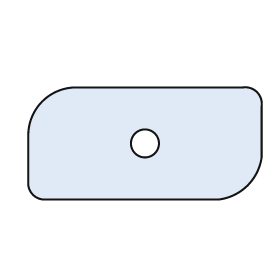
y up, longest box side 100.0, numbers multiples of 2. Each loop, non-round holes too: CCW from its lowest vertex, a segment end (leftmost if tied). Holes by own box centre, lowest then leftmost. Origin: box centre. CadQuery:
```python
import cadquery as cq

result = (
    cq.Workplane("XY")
    .moveTo(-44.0, -24.0)
    .lineTo(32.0, -24.0)
    .threePointArc((44.0, -18.0), (50.0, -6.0))
    .lineTo(50.0, 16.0)
    .threePointArc((48.0, 22.0), (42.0, 24.0))
    .lineTo(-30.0, 24.0)
    .threePointArc((-44.0, 18.0), (-50.0, 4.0))
    .lineTo(-50.0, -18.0)
    .threePointArc((-48.0, -22.0), (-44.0, -24.0))
    .close()
    .moveTo(0.0, 0.0)
    .circle(6.0)
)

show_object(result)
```